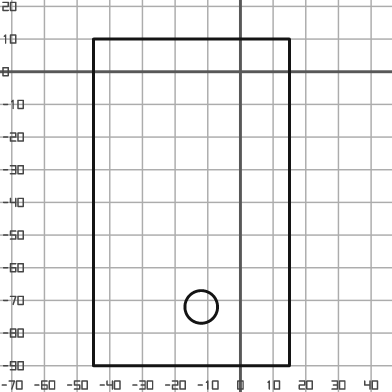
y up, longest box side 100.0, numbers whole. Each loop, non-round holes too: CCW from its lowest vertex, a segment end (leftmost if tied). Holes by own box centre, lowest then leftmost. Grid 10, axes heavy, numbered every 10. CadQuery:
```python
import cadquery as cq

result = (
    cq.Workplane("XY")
    .moveTo(-45.0, -90.0)
    .lineTo(15.0, -90.0)
    .lineTo(15.0, 10.0)
    .lineTo(-45.0, 10.0)
    .close()
    .moveTo(-12.0, -72.0)
    .circle(5.0)
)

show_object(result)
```